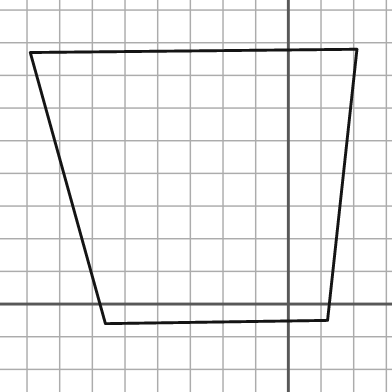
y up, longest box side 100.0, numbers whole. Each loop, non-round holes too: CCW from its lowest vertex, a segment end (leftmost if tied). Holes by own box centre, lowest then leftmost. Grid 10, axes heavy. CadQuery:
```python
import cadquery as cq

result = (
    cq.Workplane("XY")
    .moveTo(-56.0, -6.0)
    .lineTo(12.0, -5.0)
    .lineTo(21.0, 78.0)
    .lineTo(-79.0, 77.0)
    .close()
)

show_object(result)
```